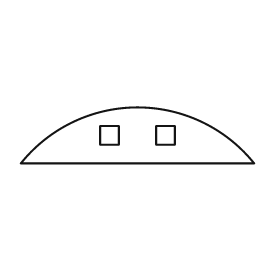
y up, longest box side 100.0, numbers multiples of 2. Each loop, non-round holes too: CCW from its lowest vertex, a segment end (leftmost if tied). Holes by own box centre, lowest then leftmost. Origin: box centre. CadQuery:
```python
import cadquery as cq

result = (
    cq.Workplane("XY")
    .moveTo(-50.0, -12.0)
    .lineTo(50.0, -12.0)
    .threePointArc((0.0, 12.0), (-50.0, -12.0))
    .close()
    .moveTo(-16.0, -4.0)
    .lineTo(-8.0, -4.0)
    .lineTo(-8.0, 4.0)
    .lineTo(-16.0, 4.0)
    .close()
    .moveTo(8.0, -4.0)
    .lineTo(16.0, -4.0)
    .lineTo(16.0, 4.0)
    .lineTo(8.0, 4.0)
    .close()
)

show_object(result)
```